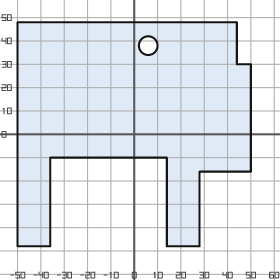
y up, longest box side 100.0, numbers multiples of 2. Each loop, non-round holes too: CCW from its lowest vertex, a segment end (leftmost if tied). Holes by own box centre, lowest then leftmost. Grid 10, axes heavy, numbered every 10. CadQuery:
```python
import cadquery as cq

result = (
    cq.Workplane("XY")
    .moveTo(-50.0, -48.0)
    .lineTo(-36.0, -48.0)
    .lineTo(-36.0, -10.0)
    .lineTo(14.0, -10.0)
    .lineTo(14.0, -48.0)
    .lineTo(28.0, -48.0)
    .lineTo(28.0, -16.0)
    .lineTo(50.0, -16.0)
    .lineTo(50.0, 30.0)
    .lineTo(44.0, 30.0)
    .lineTo(44.0, 48.0)
    .lineTo(-50.0, 48.0)
    .close()
    .moveTo(6.0, 38.0)
    .circle(4.0)
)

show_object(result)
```